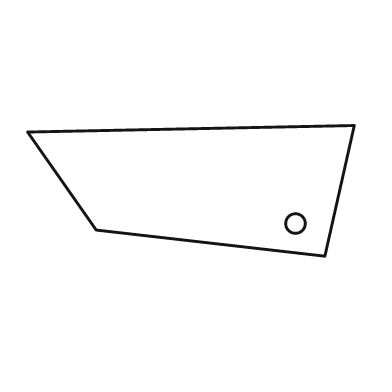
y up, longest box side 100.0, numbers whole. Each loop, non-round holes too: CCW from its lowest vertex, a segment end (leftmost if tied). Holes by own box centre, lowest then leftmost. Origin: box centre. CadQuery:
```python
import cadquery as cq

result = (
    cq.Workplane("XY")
    .moveTo(41.0, -20.0)
    .lineTo(50.0, 20.0)
    .lineTo(-50.0, 18.0)
    .lineTo(-29.0, -12.0)
    .close()
    .moveTo(32.0, -10.0)
    .circle(3.0)
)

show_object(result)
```